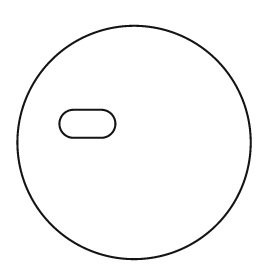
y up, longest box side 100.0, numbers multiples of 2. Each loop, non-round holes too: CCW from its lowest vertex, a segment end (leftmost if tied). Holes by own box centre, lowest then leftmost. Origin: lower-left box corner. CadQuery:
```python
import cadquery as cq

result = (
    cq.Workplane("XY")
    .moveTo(50.0, 50.0)
    .circle(50.0)
    .moveTo(24.0, 52.0)
    .lineTo(36.0, 52.0)
    .threePointArc((42.0, 58.0), (36.0, 64.0))
    .lineTo(24.0, 64.0)
    .threePointArc((18.0, 58.0), (24.0, 52.0))
    .close()
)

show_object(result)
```